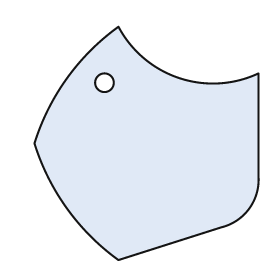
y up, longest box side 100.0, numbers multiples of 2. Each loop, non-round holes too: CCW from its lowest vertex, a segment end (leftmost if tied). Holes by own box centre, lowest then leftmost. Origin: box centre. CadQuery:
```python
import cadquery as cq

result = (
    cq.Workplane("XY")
    .moveTo(-12.0, -50.0)
    .lineTo(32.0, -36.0)
    .threePointArc((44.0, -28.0), (48.0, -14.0))
    .lineTo(48.0, 30.0)
    .threePointArc((14.0, 28.0), (-12.0, 50.0))
    .threePointArc((-34.0, 28.0), (-48.0, 0.0))
    .threePointArc((-34.0, -28.0), (-12.0, -50.0))
    .close()
    .moveTo(-18.0, 26.0)
    .circle(4.0)
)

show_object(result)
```